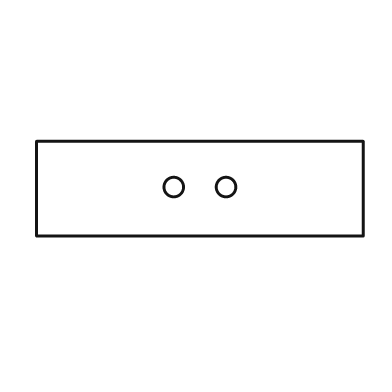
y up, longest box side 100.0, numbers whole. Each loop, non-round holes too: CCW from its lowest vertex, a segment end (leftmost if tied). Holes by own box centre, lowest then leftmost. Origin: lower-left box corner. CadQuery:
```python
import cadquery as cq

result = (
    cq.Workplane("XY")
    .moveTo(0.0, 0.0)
    .lineTo(100.0, 0.0)
    .lineTo(100.0, 29.0)
    .lineTo(0.0, 29.0)
    .close()
    .moveTo(42.0, 15.0)
    .circle(3.0)
    .moveTo(58.0, 15.0)
    .circle(3.0)
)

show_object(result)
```